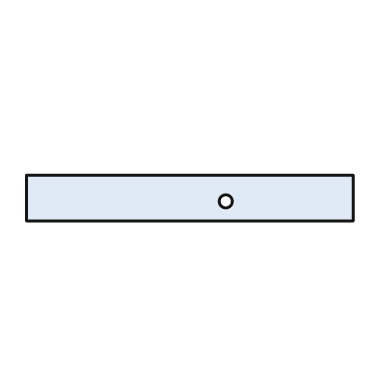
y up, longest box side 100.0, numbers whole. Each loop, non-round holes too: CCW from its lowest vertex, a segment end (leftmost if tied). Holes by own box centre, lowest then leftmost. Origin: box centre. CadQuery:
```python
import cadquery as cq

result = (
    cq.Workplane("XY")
    .moveTo(-50.0, -7.0)
    .lineTo(50.0, -7.0)
    .lineTo(50.0, 7.0)
    .lineTo(-50.0, 7.0)
    .close()
    .moveTo(11.0, -1.0)
    .circle(2.0)
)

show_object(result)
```